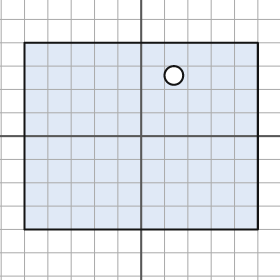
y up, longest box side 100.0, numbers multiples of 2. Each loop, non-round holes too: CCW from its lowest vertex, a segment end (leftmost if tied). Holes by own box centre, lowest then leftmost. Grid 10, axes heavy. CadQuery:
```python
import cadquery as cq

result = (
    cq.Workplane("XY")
    .moveTo(-50.0, -40.0)
    .lineTo(50.0, -40.0)
    .lineTo(50.0, 40.0)
    .lineTo(-50.0, 40.0)
    .close()
    .moveTo(14.0, 26.0)
    .circle(4.0)
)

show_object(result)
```